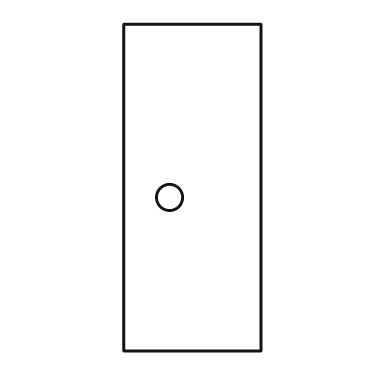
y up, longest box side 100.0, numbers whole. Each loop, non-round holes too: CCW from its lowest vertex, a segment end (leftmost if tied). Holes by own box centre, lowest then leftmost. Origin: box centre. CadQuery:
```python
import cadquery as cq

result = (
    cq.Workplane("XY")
    .moveTo(-21.0, -50.0)
    .lineTo(21.0, -50.0)
    .lineTo(21.0, 50.0)
    .lineTo(-21.0, 50.0)
    .close()
    .moveTo(-7.0, -3.0)
    .circle(4.0)
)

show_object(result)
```